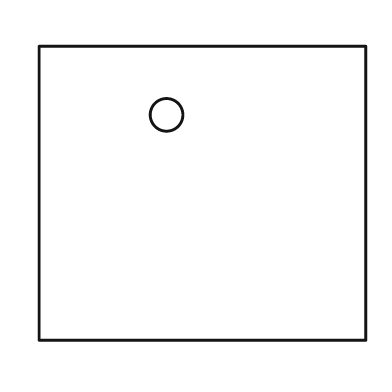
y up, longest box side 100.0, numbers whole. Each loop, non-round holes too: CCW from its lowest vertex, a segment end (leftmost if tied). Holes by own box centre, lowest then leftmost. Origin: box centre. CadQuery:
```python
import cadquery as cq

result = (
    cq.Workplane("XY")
    .moveTo(-50.0, -45.0)
    .lineTo(50.0, -45.0)
    .lineTo(50.0, 45.0)
    .lineTo(-50.0, 45.0)
    .close()
    .moveTo(-11.0, 24.0)
    .circle(5.0)
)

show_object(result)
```